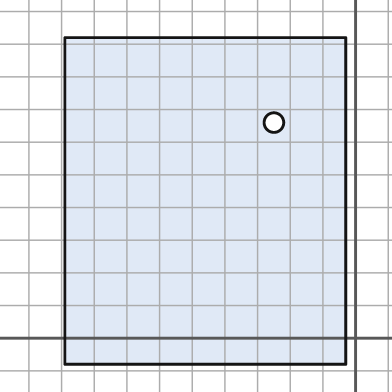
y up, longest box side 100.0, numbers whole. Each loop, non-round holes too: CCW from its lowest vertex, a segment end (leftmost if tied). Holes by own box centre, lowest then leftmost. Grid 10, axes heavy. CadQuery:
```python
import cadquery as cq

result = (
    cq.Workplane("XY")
    .moveTo(-89.0, -8.0)
    .lineTo(-3.0, -8.0)
    .lineTo(-3.0, 92.0)
    .lineTo(-89.0, 92.0)
    .close()
    .moveTo(-25.0, 66.0)
    .circle(3.0)
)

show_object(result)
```